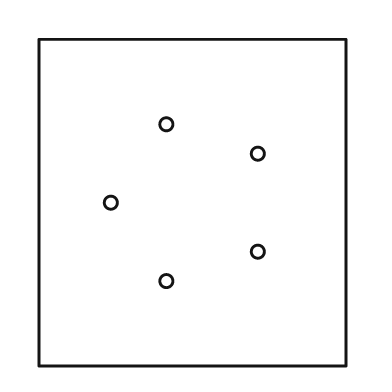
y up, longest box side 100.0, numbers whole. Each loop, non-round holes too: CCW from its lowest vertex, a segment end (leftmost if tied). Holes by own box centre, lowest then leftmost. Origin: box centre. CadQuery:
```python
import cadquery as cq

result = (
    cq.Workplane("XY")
    .moveTo(-47.0, -50.0)
    .lineTo(47.0, -50.0)
    .lineTo(47.0, 50.0)
    .lineTo(-47.0, 50.0)
    .close()
    .moveTo(-8.0, -24.0)
    .circle(2.0)
    .moveTo(20.0, -15.0)
    .circle(2.0)
    .moveTo(-25.0, 0.0)
    .circle(2.0)
    .moveTo(20.0, 15.0)
    .circle(2.0)
    .moveTo(-8.0, 24.0)
    .circle(2.0)
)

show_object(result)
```